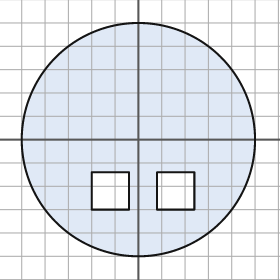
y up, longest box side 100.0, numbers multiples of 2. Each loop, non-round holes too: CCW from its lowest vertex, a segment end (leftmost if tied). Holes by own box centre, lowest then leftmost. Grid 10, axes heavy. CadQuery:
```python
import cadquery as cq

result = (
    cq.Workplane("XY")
    .moveTo(0.0, 0.0)
    .circle(50.0)
    .moveTo(-20.0, -30.0)
    .lineTo(-4.0, -30.0)
    .lineTo(-4.0, -14.0)
    .lineTo(-20.0, -14.0)
    .close()
    .moveTo(8.0, -30.0)
    .lineTo(24.0, -30.0)
    .lineTo(24.0, -14.0)
    .lineTo(8.0, -14.0)
    .close()
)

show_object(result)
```